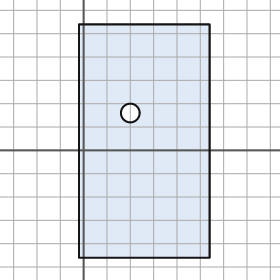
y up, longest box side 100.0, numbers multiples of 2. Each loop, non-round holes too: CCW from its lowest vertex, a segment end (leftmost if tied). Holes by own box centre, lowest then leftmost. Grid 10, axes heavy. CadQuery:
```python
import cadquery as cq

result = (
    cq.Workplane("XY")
    .moveTo(-2.0, -46.0)
    .lineTo(54.0, -46.0)
    .lineTo(54.0, 54.0)
    .lineTo(-2.0, 54.0)
    .close()
    .moveTo(20.0, 16.0)
    .circle(4.0)
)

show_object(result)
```